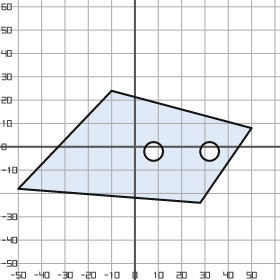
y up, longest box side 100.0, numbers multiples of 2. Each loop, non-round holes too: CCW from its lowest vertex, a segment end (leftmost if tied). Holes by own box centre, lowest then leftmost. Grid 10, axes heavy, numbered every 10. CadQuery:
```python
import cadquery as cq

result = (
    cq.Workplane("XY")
    .moveTo(28.0, -24.0)
    .lineTo(50.0, 8.0)
    .lineTo(-10.0, 24.0)
    .lineTo(-50.0, -18.0)
    .close()
    .moveTo(8.0, -2.0)
    .circle(4.0)
    .moveTo(32.0, -2.0)
    .circle(4.0)
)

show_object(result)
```